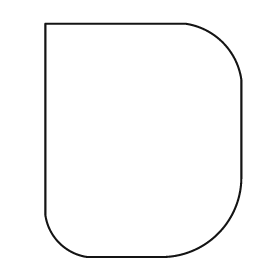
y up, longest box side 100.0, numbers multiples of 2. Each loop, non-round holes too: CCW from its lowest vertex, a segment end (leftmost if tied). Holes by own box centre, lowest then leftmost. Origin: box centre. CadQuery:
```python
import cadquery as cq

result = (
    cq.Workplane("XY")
    .moveTo(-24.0, -50.0)
    .lineTo(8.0, -50.0)
    .threePointArc((32.0, -40.0), (42.0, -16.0))
    .lineTo(42.0, 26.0)
    .threePointArc((34.0, 42.0), (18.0, 50.0))
    .lineTo(-42.0, 50.0)
    .lineTo(-42.0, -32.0)
    .threePointArc((-36.0, -44.0), (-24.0, -50.0))
    .close()
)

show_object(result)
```